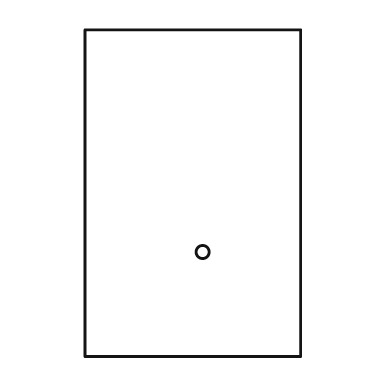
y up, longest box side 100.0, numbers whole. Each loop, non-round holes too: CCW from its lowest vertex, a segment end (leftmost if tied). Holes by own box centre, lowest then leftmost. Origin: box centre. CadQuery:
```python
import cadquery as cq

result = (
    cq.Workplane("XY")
    .moveTo(-33.0, -50.0)
    .lineTo(33.0, -50.0)
    .lineTo(33.0, 50.0)
    .lineTo(-33.0, 50.0)
    .close()
    .moveTo(3.0, -18.0)
    .circle(2.0)
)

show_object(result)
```